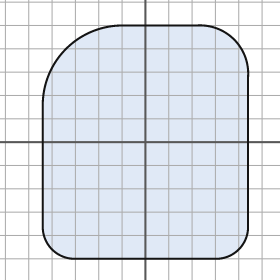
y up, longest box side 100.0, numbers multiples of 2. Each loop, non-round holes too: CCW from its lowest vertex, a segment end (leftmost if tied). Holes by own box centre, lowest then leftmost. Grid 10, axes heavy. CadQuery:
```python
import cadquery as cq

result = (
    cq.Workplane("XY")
    .moveTo(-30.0, -50.0)
    .lineTo(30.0, -50.0)
    .threePointArc((40.0, -46.0), (44.0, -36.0))
    .lineTo(44.0, 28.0)
    .threePointArc((38.0, 44.0), (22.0, 50.0))
    .lineTo(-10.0, 50.0)
    .threePointArc((-34.0, 40.0), (-44.0, 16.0))
    .lineTo(-44.0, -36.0)
    .threePointArc((-40.0, -46.0), (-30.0, -50.0))
    .close()
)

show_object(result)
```